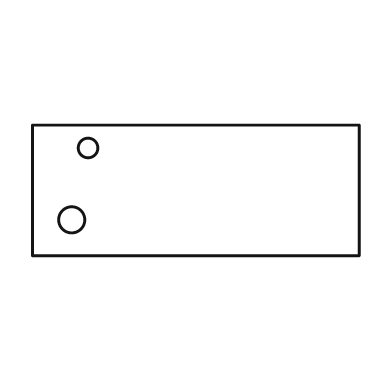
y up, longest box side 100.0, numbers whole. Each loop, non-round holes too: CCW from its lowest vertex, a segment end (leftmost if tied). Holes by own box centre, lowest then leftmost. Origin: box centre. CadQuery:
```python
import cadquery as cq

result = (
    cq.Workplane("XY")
    .moveTo(-50.0, -20.0)
    .lineTo(50.0, -20.0)
    .lineTo(50.0, 20.0)
    .lineTo(-50.0, 20.0)
    .close()
    .moveTo(-38.0, -9.0)
    .circle(4.0)
    .moveTo(-33.0, 13.0)
    .circle(3.0)
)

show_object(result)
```